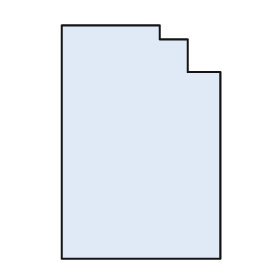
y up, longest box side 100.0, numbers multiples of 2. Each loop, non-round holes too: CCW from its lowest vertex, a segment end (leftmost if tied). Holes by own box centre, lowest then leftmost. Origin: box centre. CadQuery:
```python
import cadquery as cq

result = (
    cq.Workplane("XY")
    .moveTo(-34.0, -50.0)
    .lineTo(34.0, -50.0)
    .lineTo(34.0, 30.0)
    .lineTo(20.0, 30.0)
    .lineTo(20.0, 44.0)
    .lineTo(8.0, 44.0)
    .lineTo(8.0, 50.0)
    .lineTo(-34.0, 50.0)
    .close()
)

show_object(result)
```